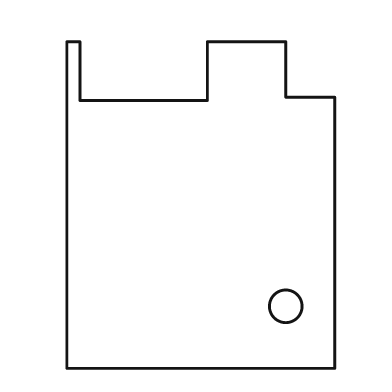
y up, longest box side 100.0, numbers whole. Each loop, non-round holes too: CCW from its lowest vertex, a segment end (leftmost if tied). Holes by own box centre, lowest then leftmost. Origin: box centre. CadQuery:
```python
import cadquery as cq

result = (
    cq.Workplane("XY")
    .moveTo(-41.0, -50.0)
    .lineTo(41.0, -50.0)
    .lineTo(41.0, 33.0)
    .lineTo(26.0, 33.0)
    .lineTo(26.0, 50.0)
    .lineTo(2.0, 50.0)
    .lineTo(2.0, 32.0)
    .lineTo(-37.0, 32.0)
    .lineTo(-37.0, 50.0)
    .lineTo(-41.0, 50.0)
    .close()
    .moveTo(26.0, -31.0)
    .circle(5.0)
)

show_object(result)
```